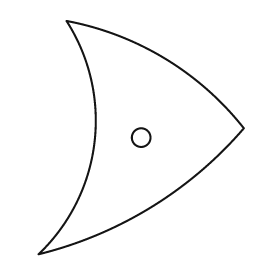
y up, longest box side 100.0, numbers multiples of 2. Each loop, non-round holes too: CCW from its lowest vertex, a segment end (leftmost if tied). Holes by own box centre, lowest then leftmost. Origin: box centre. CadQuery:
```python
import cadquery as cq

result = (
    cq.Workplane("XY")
    .moveTo(-44.0, -50.0)
    .threePointArc((4.0, -30.0), (44.0, 4.0))
    .threePointArc((10.0, 34.0), (-32.0, 50.0))
    .threePointArc((-20.0, -2.0), (-44.0, -50.0))
    .close()
    .moveTo(0.0, 0.0)
    .circle(4.0)
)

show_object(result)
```